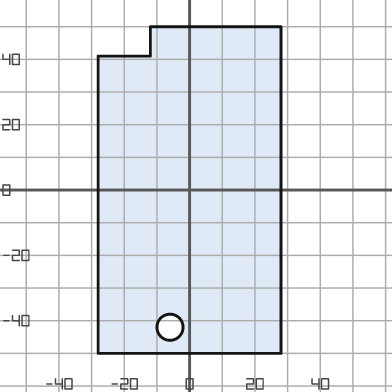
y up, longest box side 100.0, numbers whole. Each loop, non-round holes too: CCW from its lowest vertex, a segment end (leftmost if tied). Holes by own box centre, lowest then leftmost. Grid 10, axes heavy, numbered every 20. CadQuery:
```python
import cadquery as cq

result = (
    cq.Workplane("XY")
    .moveTo(-28.0, -50.0)
    .lineTo(28.0, -50.0)
    .lineTo(28.0, 50.0)
    .lineTo(-12.0, 50.0)
    .lineTo(-12.0, 41.0)
    .lineTo(-28.0, 41.0)
    .close()
    .moveTo(-6.0, -42.0)
    .circle(4.0)
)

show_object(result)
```